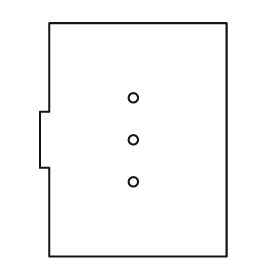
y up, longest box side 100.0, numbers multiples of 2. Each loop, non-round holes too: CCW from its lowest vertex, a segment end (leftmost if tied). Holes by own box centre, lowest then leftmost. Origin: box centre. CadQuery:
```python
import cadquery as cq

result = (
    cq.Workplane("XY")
    .moveTo(-36.0, -50.0)
    .lineTo(40.0, -50.0)
    .lineTo(40.0, 50.0)
    .lineTo(-36.0, 50.0)
    .lineTo(-36.0, 12.0)
    .lineTo(-40.0, 12.0)
    .lineTo(-40.0, -12.0)
    .lineTo(-36.0, -12.0)
    .close()
    .moveTo(0.0, -18.0)
    .circle(2.0)
    .moveTo(0.0, 0.0)
    .circle(2.0)
    .moveTo(0.0, 18.0)
    .circle(2.0)
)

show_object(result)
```